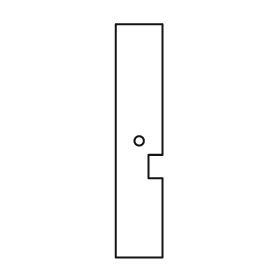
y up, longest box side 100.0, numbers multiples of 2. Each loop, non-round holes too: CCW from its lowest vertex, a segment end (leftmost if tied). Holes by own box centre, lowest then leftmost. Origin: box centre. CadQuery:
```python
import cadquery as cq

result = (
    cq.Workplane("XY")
    .moveTo(-10.0, -50.0)
    .lineTo(10.0, -50.0)
    .lineTo(10.0, -16.0)
    .lineTo(4.0, -16.0)
    .lineTo(4.0, -6.0)
    .lineTo(10.0, -6.0)
    .lineTo(10.0, 50.0)
    .lineTo(-10.0, 50.0)
    .close()
    .moveTo(0.0, 0.0)
    .circle(2.0)
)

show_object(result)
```